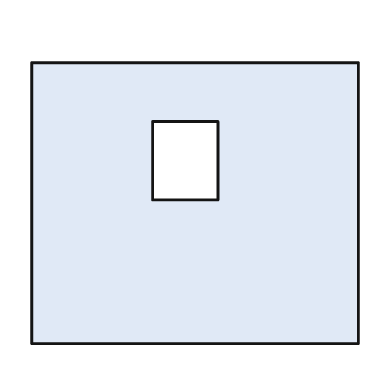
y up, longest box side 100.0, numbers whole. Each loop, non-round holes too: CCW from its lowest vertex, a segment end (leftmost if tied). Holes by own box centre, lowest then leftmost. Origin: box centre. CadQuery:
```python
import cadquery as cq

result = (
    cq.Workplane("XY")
    .moveTo(-50.0, -43.0)
    .lineTo(50.0, -43.0)
    .lineTo(50.0, 43.0)
    .lineTo(-50.0, 43.0)
    .close()
    .moveTo(-13.0, 1.0)
    .lineTo(7.0, 1.0)
    .lineTo(7.0, 25.0)
    .lineTo(-13.0, 25.0)
    .close()
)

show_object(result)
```